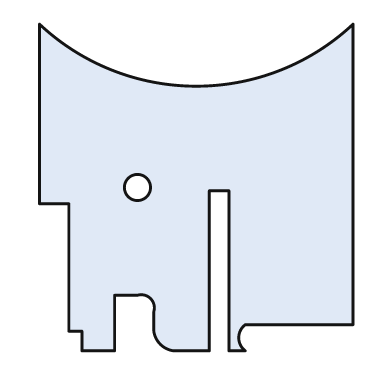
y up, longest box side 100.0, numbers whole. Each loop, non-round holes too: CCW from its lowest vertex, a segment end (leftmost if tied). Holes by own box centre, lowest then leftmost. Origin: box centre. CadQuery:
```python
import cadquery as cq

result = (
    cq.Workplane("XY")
    .moveTo(-35.0, -50.0)
    .lineTo(-25.0, -50.0)
    .lineTo(-25.0, -33.0)
    .lineTo(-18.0, -33.0)
    .threePointArc((-14.0, -34.0), (-13.0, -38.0))
    .lineTo(-13.0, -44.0)
    .threePointArc((-11.0, -48.0), (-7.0, -50.0))
    .lineTo(4.0, -50.0)
    .lineTo(4.0, -1.0)
    .lineTo(10.0, -1.0)
    .lineTo(10.0, -50.0)
    .lineTo(15.0, -50.0)
    .threePointArc((13.0, -46.0), (15.0, -42.0))
    .lineTo(48.0, -42.0)
    .lineTo(48.0, 50.0)
    .threePointArc((0.0, 31.0), (-48.0, 50.0))
    .lineTo(-48.0, -5.0)
    .lineTo(-39.0, -5.0)
    .lineTo(-39.0, -44.0)
    .lineTo(-35.0, -44.0)
    .close()
    .moveTo(-18.0, 0.0)
    .circle(4.0)
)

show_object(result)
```